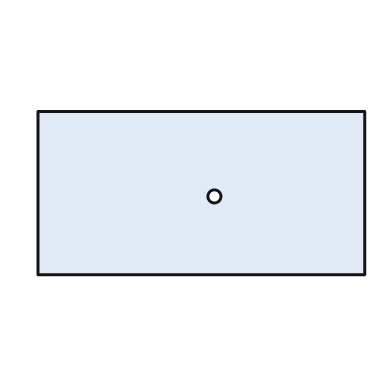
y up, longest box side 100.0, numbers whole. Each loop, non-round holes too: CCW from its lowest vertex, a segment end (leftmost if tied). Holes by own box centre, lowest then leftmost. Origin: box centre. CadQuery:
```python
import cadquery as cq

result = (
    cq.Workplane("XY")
    .moveTo(-50.0, -25.0)
    .lineTo(50.0, -25.0)
    .lineTo(50.0, 25.0)
    .lineTo(-50.0, 25.0)
    .close()
    .moveTo(4.0, -1.0)
    .circle(2.0)
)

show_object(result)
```